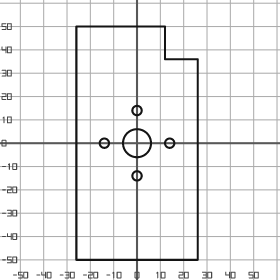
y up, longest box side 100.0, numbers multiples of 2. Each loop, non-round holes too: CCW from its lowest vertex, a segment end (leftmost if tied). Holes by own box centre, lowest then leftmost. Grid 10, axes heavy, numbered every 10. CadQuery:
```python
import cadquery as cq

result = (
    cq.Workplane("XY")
    .moveTo(-26.0, -50.0)
    .lineTo(26.0, -50.0)
    .lineTo(26.0, 36.0)
    .lineTo(12.0, 36.0)
    .lineTo(12.0, 50.0)
    .lineTo(-26.0, 50.0)
    .close()
    .moveTo(0.0, -14.0)
    .circle(2.0)
    .moveTo(-14.0, 0.0)
    .circle(2.0)
    .moveTo(0.0, 0.0)
    .circle(6.0)
    .moveTo(14.0, 0.0)
    .circle(2.0)
    .moveTo(0.0, 14.0)
    .circle(2.0)
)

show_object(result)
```